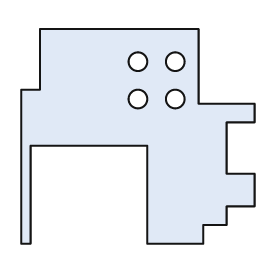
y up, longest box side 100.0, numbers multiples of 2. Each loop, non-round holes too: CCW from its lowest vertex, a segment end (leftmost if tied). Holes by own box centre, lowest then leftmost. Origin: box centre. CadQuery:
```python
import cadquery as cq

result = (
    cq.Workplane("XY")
    .moveTo(-50.0, -46.0)
    .lineTo(-46.0, -46.0)
    .lineTo(-46.0, -4.0)
    .lineTo(4.0, -4.0)
    .lineTo(4.0, -46.0)
    .lineTo(28.0, -46.0)
    .lineTo(28.0, -38.0)
    .lineTo(38.0, -38.0)
    .lineTo(38.0, -30.0)
    .lineTo(50.0, -30.0)
    .lineTo(50.0, -16.0)
    .lineTo(38.0, -16.0)
    .lineTo(38.0, 6.0)
    .lineTo(50.0, 6.0)
    .lineTo(50.0, 14.0)
    .lineTo(26.0, 14.0)
    .lineTo(26.0, 46.0)
    .lineTo(-42.0, 46.0)
    .lineTo(-42.0, 20.0)
    .lineTo(-50.0, 20.0)
    .close()
    .moveTo(0.0, 16.0)
    .circle(4.0)
    .moveTo(16.0, 16.0)
    .circle(4.0)
    .moveTo(0.0, 32.0)
    .circle(4.0)
    .moveTo(16.0, 32.0)
    .circle(4.0)
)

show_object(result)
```